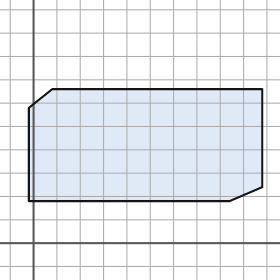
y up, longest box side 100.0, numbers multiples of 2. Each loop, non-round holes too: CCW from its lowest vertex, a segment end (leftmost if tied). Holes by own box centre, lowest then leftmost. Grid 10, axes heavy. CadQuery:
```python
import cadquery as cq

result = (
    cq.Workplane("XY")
    .moveTo(-2.0, 18.0)
    .lineTo(84.0, 18.0)
    .lineTo(98.0, 24.0)
    .lineTo(98.0, 66.0)
    .lineTo(8.0, 66.0)
    .lineTo(-2.0, 58.0)
    .close()
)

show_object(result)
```